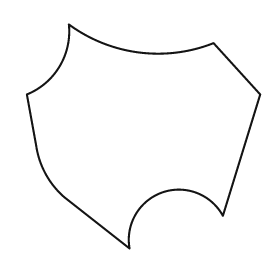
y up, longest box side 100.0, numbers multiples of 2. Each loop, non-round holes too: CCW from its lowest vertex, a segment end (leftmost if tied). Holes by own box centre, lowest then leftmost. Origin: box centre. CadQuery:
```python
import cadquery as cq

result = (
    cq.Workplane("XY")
    .moveTo(-6.0, -48.0)
    .threePointArc((8.0, -24.0), (34.0, -34.0))
    .lineTo(50.0, 18.0)
    .lineTo(30.0, 40.0)
    .threePointArc((-2.0, 36.0), (-32.0, 48.0))
    .threePointArc((-36.0, 30.0), (-50.0, 18.0))
    .lineTo(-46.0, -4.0)
    .threePointArc((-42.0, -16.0), (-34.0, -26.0))
    .close()
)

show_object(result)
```